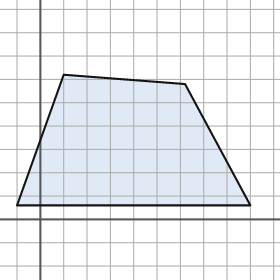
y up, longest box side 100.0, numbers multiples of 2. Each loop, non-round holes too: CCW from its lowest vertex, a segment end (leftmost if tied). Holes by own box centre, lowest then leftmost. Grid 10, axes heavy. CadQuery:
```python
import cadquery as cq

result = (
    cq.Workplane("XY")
    .moveTo(-10.0, 6.0)
    .lineTo(90.0, 6.0)
    .lineTo(62.0, 58.0)
    .lineTo(10.0, 62.0)
    .close()
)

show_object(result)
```